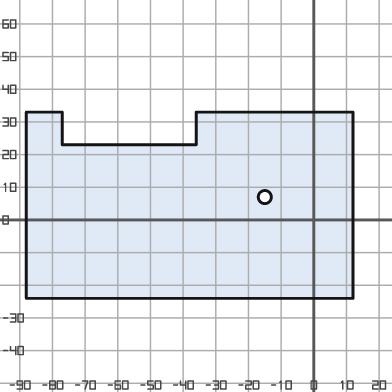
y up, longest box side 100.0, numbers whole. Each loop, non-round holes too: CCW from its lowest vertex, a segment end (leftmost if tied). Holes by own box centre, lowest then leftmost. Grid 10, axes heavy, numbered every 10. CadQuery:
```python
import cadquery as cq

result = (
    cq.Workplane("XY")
    .moveTo(-88.0, -24.0)
    .lineTo(12.0, -24.0)
    .lineTo(12.0, 33.0)
    .lineTo(-36.0, 33.0)
    .lineTo(-36.0, 23.0)
    .lineTo(-77.0, 23.0)
    .lineTo(-77.0, 33.0)
    .lineTo(-88.0, 33.0)
    .close()
    .moveTo(-15.0, 7.0)
    .circle(2.0)
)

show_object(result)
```